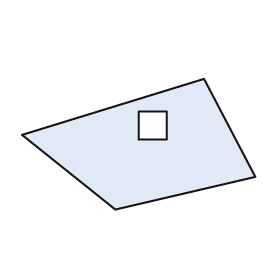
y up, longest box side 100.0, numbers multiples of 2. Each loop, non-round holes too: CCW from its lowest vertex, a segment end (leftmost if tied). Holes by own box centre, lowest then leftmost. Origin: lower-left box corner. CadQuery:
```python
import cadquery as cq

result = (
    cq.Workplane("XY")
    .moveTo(40.0, 0.0)
    .lineTo(100.0, 14.0)
    .lineTo(78.0, 56.0)
    .lineTo(0.0, 32.0)
    .close()
    .moveTo(50.0, 30.0)
    .lineTo(62.0, 30.0)
    .lineTo(62.0, 42.0)
    .lineTo(50.0, 42.0)
    .close()
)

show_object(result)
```